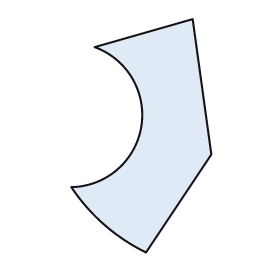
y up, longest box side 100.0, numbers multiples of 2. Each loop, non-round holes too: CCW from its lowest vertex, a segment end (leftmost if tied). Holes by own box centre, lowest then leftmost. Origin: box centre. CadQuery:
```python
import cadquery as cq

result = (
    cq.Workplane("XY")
    .moveTo(2.0, -50.0)
    .lineTo(30.0, -8.0)
    .lineTo(22.0, 50.0)
    .lineTo(-20.0, 38.0)
    .threePointArc((0.0, 4.0), (-30.0, -22.0))
    .threePointArc((-16.0, -38.0), (2.0, -50.0))
    .close()
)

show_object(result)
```